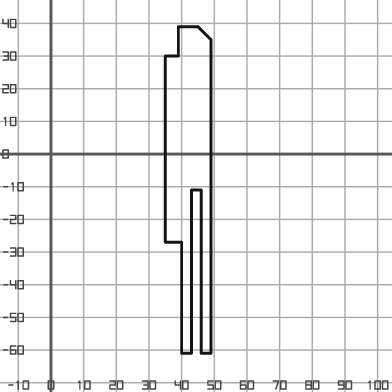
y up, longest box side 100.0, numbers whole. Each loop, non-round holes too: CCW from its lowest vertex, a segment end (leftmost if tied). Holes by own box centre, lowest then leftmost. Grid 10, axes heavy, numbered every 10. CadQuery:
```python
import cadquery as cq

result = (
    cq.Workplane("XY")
    .moveTo(40.0, -61.0)
    .lineTo(43.0, -61.0)
    .lineTo(43.0, -11.0)
    .lineTo(46.0, -11.0)
    .lineTo(46.0, -61.0)
    .lineTo(49.0, -61.0)
    .lineTo(49.0, 35.0)
    .lineTo(45.0, 39.0)
    .lineTo(39.0, 39.0)
    .lineTo(39.0, 30.0)
    .lineTo(35.0, 30.0)
    .lineTo(35.0, -27.0)
    .lineTo(40.0, -27.0)
    .close()
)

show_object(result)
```